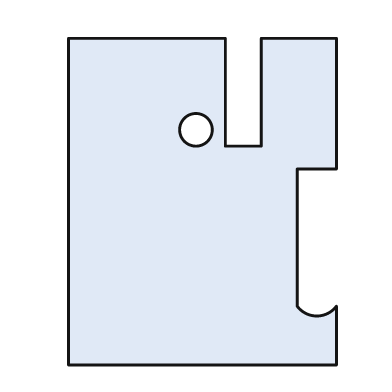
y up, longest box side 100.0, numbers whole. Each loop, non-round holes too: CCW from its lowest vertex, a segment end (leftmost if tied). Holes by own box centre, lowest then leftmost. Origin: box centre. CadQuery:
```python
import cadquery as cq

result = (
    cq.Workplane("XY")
    .moveTo(-41.0, -50.0)
    .lineTo(41.0, -50.0)
    .lineTo(41.0, -32.0)
    .threePointArc((35.0, -35.0), (29.0, -32.0))
    .lineTo(29.0, 10.0)
    .lineTo(41.0, 10.0)
    .lineTo(41.0, 50.0)
    .lineTo(18.0, 50.0)
    .lineTo(18.0, 17.0)
    .lineTo(7.0, 17.0)
    .lineTo(7.0, 50.0)
    .lineTo(-41.0, 50.0)
    .close()
    .moveTo(-2.0, 22.0)
    .circle(5.0)
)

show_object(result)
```